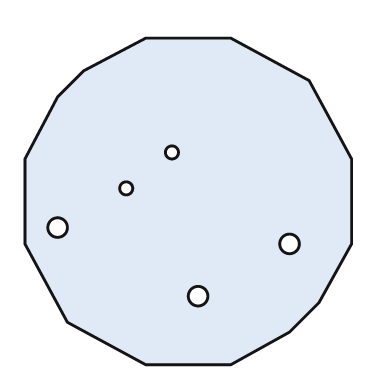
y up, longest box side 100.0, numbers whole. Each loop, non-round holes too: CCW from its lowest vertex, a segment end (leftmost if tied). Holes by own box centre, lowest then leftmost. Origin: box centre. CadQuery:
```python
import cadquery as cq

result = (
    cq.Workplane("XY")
    .moveTo(-13.0, -50.0)
    .lineTo(13.0, -50.0)
    .lineTo(31.0, -40.0)
    .lineTo(40.0, -31.0)
    .lineTo(50.0, -13.0)
    .lineTo(50.0, 13.0)
    .lineTo(37.0, 37.0)
    .lineTo(13.0, 50.0)
    .lineTo(-13.0, 50.0)
    .lineTo(-32.0, 40.0)
    .lineTo(-40.0, 32.0)
    .lineTo(-50.0, 13.0)
    .lineTo(-50.0, -13.0)
    .lineTo(-37.0, -37.0)
    .close()
    .moveTo(3.0, -29.0)
    .circle(3.0)
    .moveTo(31.0, -13.0)
    .circle(3.0)
    .moveTo(-40.0, -8.0)
    .circle(3.0)
    .moveTo(-19.0, 4.0)
    .circle(2.0)
    .moveTo(-5.0, 15.0)
    .circle(2.0)
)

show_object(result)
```